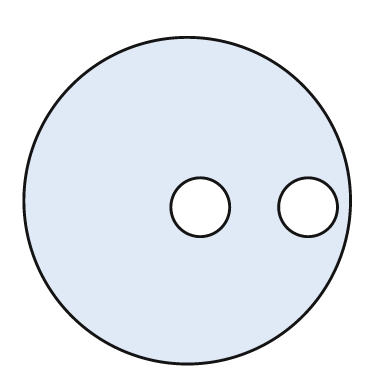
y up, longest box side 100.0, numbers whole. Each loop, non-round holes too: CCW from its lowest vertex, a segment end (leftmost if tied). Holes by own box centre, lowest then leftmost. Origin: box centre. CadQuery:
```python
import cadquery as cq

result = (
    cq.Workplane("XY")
    .moveTo(0.0, 0.0)
    .circle(50.0)
    .moveTo(4.0, -2.0)
    .circle(9.0)
    .moveTo(37.0, -2.0)
    .circle(9.0)
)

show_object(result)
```